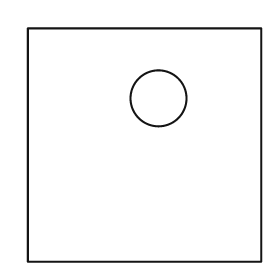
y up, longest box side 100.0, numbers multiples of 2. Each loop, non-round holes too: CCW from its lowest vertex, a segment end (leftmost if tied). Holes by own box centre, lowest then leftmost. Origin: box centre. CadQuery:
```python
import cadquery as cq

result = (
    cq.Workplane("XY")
    .moveTo(-50.0, -50.0)
    .lineTo(50.0, -50.0)
    .lineTo(50.0, 50.0)
    .lineTo(-50.0, 50.0)
    .close()
    .moveTo(6.0, 20.0)
    .circle(12.0)
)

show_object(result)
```